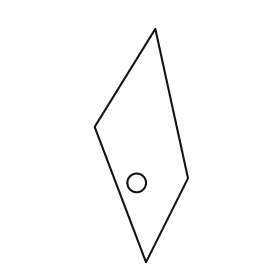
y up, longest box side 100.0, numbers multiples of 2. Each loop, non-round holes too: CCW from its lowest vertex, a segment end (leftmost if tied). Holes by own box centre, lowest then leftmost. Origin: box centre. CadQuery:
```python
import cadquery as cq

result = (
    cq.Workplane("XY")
    .moveTo(2.0, -50.0)
    .lineTo(20.0, -14.0)
    .lineTo(6.0, 50.0)
    .lineTo(-20.0, 8.0)
    .close()
    .moveTo(-2.0, -16.0)
    .circle(4.0)
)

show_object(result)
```